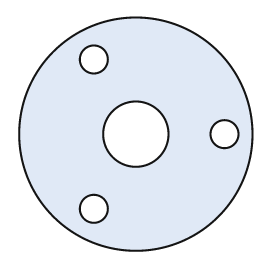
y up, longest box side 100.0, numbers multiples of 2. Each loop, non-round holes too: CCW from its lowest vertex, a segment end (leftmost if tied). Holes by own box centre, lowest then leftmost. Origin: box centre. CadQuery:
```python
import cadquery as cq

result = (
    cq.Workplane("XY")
    .moveTo(0.0, 0.0)
    .circle(50.0)
    .moveTo(-18.0, -32.0)
    .circle(6.0)
    .moveTo(0.0, 0.0)
    .circle(14.0)
    .moveTo(38.0, 0.0)
    .circle(6.0)
    .moveTo(-18.0, 32.0)
    .circle(6.0)
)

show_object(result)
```